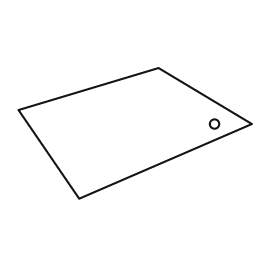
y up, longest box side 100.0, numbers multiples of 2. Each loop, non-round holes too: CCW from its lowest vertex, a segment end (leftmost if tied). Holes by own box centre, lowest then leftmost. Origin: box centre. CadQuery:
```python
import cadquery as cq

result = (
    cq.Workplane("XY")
    .moveTo(-24.0, -28.0)
    .lineTo(50.0, 4.0)
    .lineTo(10.0, 28.0)
    .lineTo(-50.0, 10.0)
    .close()
    .moveTo(34.0, 4.0)
    .circle(2.0)
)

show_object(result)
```